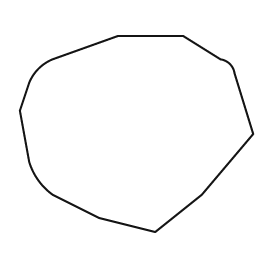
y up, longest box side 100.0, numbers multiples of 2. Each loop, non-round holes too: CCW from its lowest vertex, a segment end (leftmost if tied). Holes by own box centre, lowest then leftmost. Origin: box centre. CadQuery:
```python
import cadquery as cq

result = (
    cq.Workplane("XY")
    .moveTo(8.0, -42.0)
    .lineTo(28.0, -26.0)
    .lineTo(50.0, 0.0)
    .lineTo(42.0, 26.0)
    .threePointArc((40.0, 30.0), (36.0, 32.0))
    .lineTo(20.0, 42.0)
    .lineTo(-8.0, 42.0)
    .lineTo(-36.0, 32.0)
    .threePointArc((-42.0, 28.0), (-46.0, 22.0))
    .lineTo(-50.0, 10.0)
    .lineTo(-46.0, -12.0)
    .threePointArc((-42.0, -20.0), (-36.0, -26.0))
    .lineTo(-16.0, -36.0)
    .close()
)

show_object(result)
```